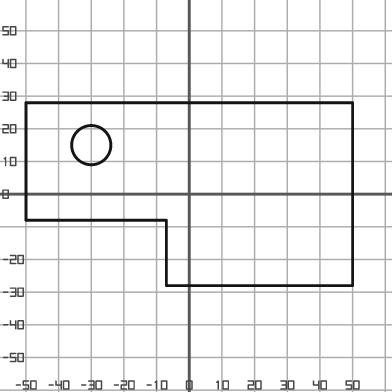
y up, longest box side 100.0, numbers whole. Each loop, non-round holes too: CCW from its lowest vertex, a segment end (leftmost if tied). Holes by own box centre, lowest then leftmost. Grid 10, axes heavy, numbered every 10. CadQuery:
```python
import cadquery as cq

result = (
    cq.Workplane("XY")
    .moveTo(-7.0, -28.0)
    .lineTo(50.0, -28.0)
    .lineTo(50.0, 28.0)
    .lineTo(-50.0, 28.0)
    .lineTo(-50.0, -8.0)
    .lineTo(-7.0, -8.0)
    .close()
    .moveTo(-30.0, 15.0)
    .circle(6.0)
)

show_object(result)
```